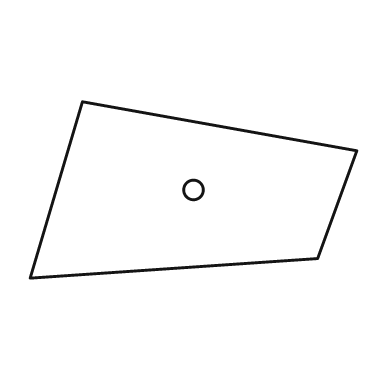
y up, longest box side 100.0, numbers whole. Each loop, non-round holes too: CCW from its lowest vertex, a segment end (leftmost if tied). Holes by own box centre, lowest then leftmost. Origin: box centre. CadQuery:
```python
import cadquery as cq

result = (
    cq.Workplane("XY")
    .moveTo(-50.0, -27.0)
    .lineTo(38.0, -21.0)
    .lineTo(50.0, 12.0)
    .lineTo(-34.0, 27.0)
    .close()
    .moveTo(0.0, 0.0)
    .circle(3.0)
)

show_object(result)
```